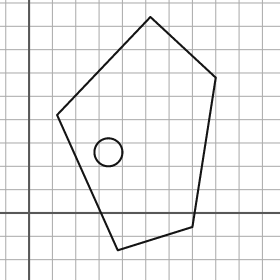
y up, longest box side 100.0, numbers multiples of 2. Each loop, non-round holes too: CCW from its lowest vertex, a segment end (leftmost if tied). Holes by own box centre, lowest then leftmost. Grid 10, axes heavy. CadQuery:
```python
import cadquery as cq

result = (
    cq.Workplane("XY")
    .moveTo(38.0, -16.0)
    .lineTo(70.0, -6.0)
    .lineTo(80.0, 58.0)
    .lineTo(52.0, 84.0)
    .lineTo(12.0, 42.0)
    .close()
    .moveTo(34.0, 26.0)
    .circle(6.0)
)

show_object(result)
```